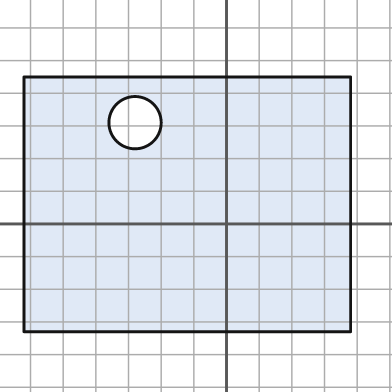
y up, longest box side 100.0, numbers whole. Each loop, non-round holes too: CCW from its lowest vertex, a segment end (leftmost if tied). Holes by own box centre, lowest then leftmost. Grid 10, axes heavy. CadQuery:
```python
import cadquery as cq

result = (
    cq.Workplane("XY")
    .moveTo(-62.0, -33.0)
    .lineTo(38.0, -33.0)
    .lineTo(38.0, 45.0)
    .lineTo(-62.0, 45.0)
    .close()
    .moveTo(-28.0, 31.0)
    .circle(8.0)
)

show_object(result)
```